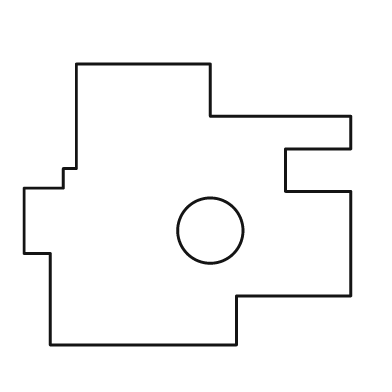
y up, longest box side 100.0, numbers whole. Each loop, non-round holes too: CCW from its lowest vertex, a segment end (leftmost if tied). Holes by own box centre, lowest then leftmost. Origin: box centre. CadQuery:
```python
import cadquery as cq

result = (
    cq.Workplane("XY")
    .moveTo(-42.0, -43.0)
    .lineTo(15.0, -43.0)
    .lineTo(15.0, -28.0)
    .lineTo(50.0, -28.0)
    .lineTo(50.0, 4.0)
    .lineTo(30.0, 4.0)
    .lineTo(30.0, 17.0)
    .lineTo(50.0, 17.0)
    .lineTo(50.0, 27.0)
    .lineTo(7.0, 27.0)
    .lineTo(7.0, 43.0)
    .lineTo(-34.0, 43.0)
    .lineTo(-34.0, 11.0)
    .lineTo(-38.0, 11.0)
    .lineTo(-38.0, 5.0)
    .lineTo(-50.0, 5.0)
    .lineTo(-50.0, -15.0)
    .lineTo(-42.0, -15.0)
    .close()
    .moveTo(7.0, -8.0)
    .circle(10.0)
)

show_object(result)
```